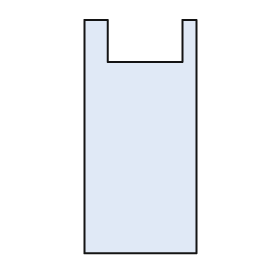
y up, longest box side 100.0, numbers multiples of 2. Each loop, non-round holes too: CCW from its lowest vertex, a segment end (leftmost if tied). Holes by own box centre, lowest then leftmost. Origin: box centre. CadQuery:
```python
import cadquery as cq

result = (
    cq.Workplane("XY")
    .moveTo(-24.0, -50.0)
    .lineTo(24.0, -50.0)
    .lineTo(24.0, 50.0)
    .lineTo(18.0, 50.0)
    .lineTo(18.0, 32.0)
    .lineTo(-14.0, 32.0)
    .lineTo(-14.0, 50.0)
    .lineTo(-24.0, 50.0)
    .close()
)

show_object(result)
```